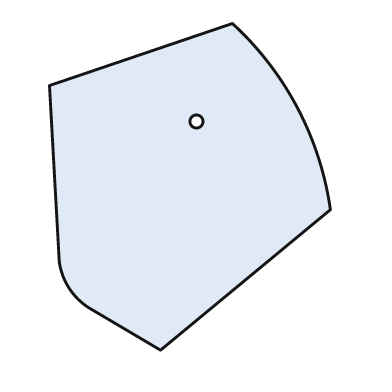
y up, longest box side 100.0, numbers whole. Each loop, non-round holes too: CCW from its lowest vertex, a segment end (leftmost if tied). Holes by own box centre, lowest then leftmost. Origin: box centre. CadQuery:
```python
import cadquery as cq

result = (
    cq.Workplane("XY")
    .moveTo(-9.0, -50.0)
    .lineTo(43.0, -7.0)
    .threePointArc((33.0, 24.0), (13.0, 50.0))
    .lineTo(-43.0, 31.0)
    .lineTo(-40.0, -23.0)
    .threePointArc((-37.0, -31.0), (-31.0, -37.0))
    .close()
    .moveTo(2.0, 20.0)
    .circle(2.0)
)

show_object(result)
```